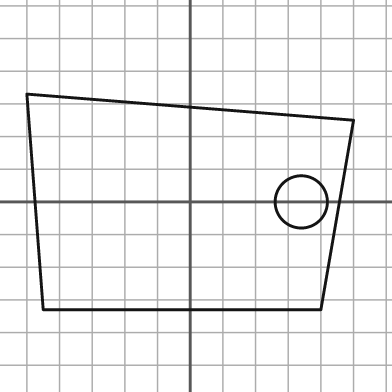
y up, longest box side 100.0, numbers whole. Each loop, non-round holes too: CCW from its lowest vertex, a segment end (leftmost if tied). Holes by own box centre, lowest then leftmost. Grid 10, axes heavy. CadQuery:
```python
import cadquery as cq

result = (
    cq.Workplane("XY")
    .moveTo(-45.0, -33.0)
    .lineTo(40.0, -33.0)
    .lineTo(50.0, 25.0)
    .lineTo(-50.0, 33.0)
    .close()
    .moveTo(34.0, 0.0)
    .circle(8.0)
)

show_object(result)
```